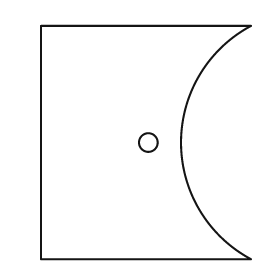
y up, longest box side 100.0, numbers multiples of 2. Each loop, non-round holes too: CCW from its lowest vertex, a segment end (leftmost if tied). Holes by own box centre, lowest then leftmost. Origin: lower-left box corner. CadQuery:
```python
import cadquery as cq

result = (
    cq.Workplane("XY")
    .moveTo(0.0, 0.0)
    .lineTo(90.0, 0.0)
    .threePointArc((60.0, 50.0), (90.0, 100.0))
    .lineTo(0.0, 100.0)
    .close()
    .moveTo(46.0, 50.0)
    .circle(4.0)
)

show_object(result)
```